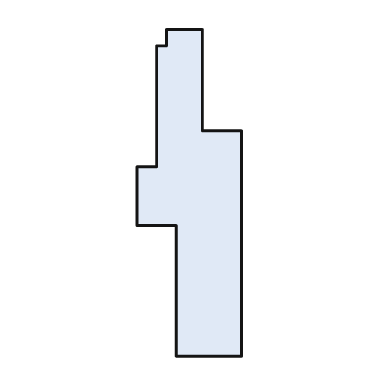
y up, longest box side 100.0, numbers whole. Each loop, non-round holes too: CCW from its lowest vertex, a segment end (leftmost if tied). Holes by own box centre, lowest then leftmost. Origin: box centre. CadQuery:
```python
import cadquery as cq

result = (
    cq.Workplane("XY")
    .moveTo(-4.0, -50.0)
    .lineTo(16.0, -50.0)
    .lineTo(16.0, 19.0)
    .lineTo(4.0, 19.0)
    .lineTo(4.0, 50.0)
    .lineTo(-7.0, 50.0)
    .lineTo(-7.0, 45.0)
    .lineTo(-10.0, 45.0)
    .lineTo(-10.0, 8.0)
    .lineTo(-16.0, 8.0)
    .lineTo(-16.0, -10.0)
    .lineTo(-4.0, -10.0)
    .close()
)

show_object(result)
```